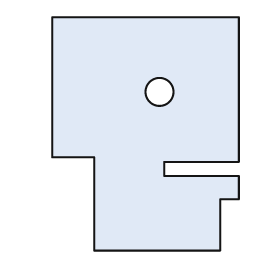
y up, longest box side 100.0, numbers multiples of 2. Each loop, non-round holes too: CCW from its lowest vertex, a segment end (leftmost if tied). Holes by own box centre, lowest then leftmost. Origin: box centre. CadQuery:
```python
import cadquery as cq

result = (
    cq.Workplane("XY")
    .moveTo(-22.0, -50.0)
    .lineTo(32.0, -50.0)
    .lineTo(32.0, -28.0)
    .lineTo(40.0, -28.0)
    .lineTo(40.0, -18.0)
    .lineTo(8.0, -18.0)
    .lineTo(8.0, -12.0)
    .lineTo(40.0, -12.0)
    .lineTo(40.0, 50.0)
    .lineTo(-40.0, 50.0)
    .lineTo(-40.0, -10.0)
    .lineTo(-22.0, -10.0)
    .close()
    .moveTo(6.0, 18.0)
    .circle(6.0)
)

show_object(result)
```